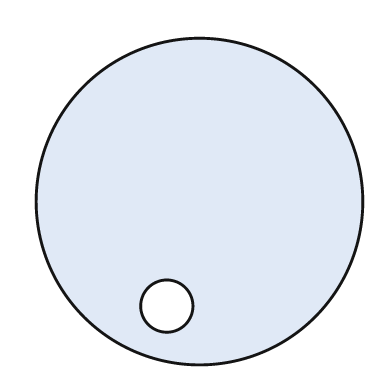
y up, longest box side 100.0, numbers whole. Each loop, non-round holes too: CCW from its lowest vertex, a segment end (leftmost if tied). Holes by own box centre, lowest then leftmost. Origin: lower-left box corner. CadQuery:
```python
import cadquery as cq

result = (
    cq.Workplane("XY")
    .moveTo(50.0, 50.0)
    .circle(50.0)
    .moveTo(40.0, 18.0)
    .circle(8.0)
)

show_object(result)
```